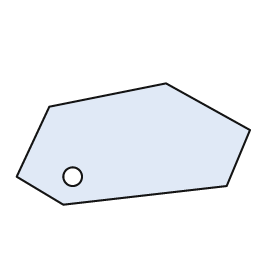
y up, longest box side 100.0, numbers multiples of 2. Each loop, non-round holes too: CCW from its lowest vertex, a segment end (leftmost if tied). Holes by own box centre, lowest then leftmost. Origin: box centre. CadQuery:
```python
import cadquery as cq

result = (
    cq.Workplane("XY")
    .moveTo(-30.0, -26.0)
    .lineTo(40.0, -18.0)
    .lineTo(50.0, 6.0)
    .lineTo(14.0, 26.0)
    .lineTo(-36.0, 16.0)
    .lineTo(-50.0, -14.0)
    .close()
    .moveTo(-26.0, -14.0)
    .circle(4.0)
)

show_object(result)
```